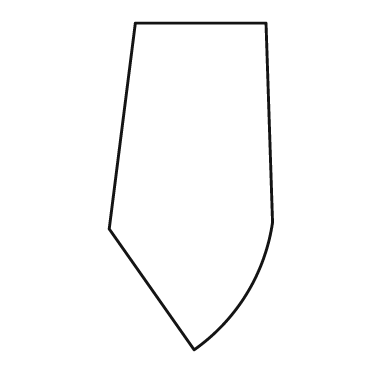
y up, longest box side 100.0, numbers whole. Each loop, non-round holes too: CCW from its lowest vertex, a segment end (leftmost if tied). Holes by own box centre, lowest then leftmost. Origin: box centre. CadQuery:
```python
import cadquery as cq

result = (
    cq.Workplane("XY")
    .moveTo(1.0, -50.0)
    .threePointArc((17.0, -33.0), (25.0, -11.0))
    .lineTo(23.0, 50.0)
    .lineTo(-17.0, 50.0)
    .lineTo(-25.0, -13.0)
    .close()
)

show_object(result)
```